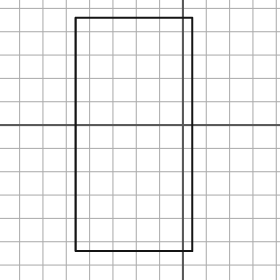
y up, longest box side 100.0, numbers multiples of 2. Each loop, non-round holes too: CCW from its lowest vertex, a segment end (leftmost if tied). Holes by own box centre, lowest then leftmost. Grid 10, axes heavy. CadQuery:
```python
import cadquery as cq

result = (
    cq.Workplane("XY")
    .moveTo(-46.0, -54.0)
    .lineTo(4.0, -54.0)
    .lineTo(4.0, 46.0)
    .lineTo(-46.0, 46.0)
    .close()
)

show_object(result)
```